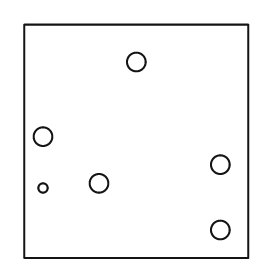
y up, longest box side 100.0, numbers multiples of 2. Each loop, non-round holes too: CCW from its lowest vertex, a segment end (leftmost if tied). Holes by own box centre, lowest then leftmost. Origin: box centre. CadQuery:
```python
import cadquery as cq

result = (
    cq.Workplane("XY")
    .moveTo(-48.0, -50.0)
    .lineTo(48.0, -50.0)
    .lineTo(48.0, 50.0)
    .lineTo(-48.0, 50.0)
    .close()
    .moveTo(36.0, -38.0)
    .circle(4.0)
    .moveTo(-40.0, -20.0)
    .circle(2.0)
    .moveTo(-16.0, -18.0)
    .circle(4.0)
    .moveTo(36.0, -10.0)
    .circle(4.0)
    .moveTo(-40.0, 2.0)
    .circle(4.0)
    .moveTo(0.0, 34.0)
    .circle(4.0)
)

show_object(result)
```